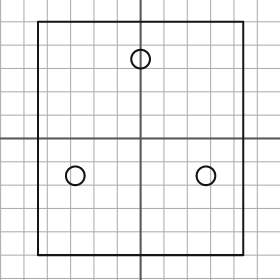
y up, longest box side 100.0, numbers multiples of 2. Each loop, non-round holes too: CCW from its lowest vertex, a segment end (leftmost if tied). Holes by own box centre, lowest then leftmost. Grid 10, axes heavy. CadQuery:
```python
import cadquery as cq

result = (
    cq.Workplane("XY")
    .moveTo(-44.0, -50.0)
    .lineTo(44.0, -50.0)
    .lineTo(44.0, 50.0)
    .lineTo(-44.0, 50.0)
    .close()
    .moveTo(-28.0, -16.0)
    .circle(4.0)
    .moveTo(28.0, -16.0)
    .circle(4.0)
    .moveTo(0.0, 34.0)
    .circle(4.0)
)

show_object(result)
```